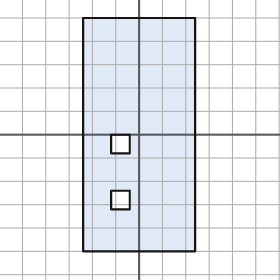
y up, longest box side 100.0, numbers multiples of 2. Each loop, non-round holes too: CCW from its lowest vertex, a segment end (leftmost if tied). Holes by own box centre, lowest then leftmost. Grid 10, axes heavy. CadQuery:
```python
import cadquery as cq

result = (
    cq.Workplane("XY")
    .moveTo(-24.0, -50.0)
    .lineTo(24.0, -50.0)
    .lineTo(24.0, 50.0)
    .lineTo(-24.0, 50.0)
    .close()
    .moveTo(-12.0, -32.0)
    .lineTo(-4.0, -32.0)
    .lineTo(-4.0, -24.0)
    .lineTo(-12.0, -24.0)
    .close()
    .moveTo(-12.0, -8.0)
    .lineTo(-4.0, -8.0)
    .lineTo(-4.0, 0.0)
    .lineTo(-12.0, 0.0)
    .close()
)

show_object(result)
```